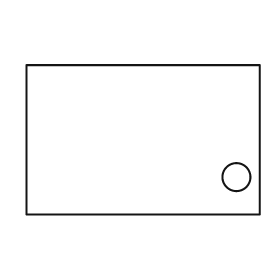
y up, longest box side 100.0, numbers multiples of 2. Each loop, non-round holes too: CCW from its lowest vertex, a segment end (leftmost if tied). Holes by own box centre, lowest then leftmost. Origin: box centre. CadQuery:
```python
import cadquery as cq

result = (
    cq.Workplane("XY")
    .moveTo(-50.0, -32.0)
    .lineTo(50.0, -32.0)
    .lineTo(50.0, 32.0)
    .lineTo(-50.0, 32.0)
    .close()
    .moveTo(40.0, -16.0)
    .circle(6.0)
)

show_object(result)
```